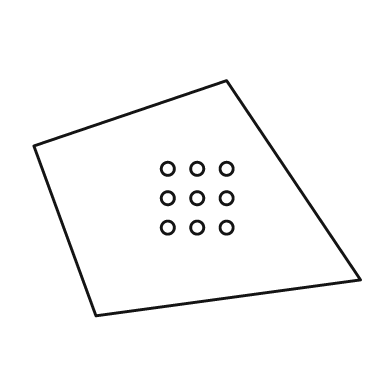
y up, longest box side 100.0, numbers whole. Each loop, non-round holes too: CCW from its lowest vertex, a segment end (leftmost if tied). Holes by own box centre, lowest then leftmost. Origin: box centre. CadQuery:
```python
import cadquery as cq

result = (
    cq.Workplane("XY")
    .moveTo(-31.0, -36.0)
    .lineTo(50.0, -25.0)
    .lineTo(9.0, 36.0)
    .lineTo(-50.0, 16.0)
    .close()
    .moveTo(-9.0, -9.0)
    .circle(2.0)
    .moveTo(0.0, -9.0)
    .circle(2.0)
    .moveTo(9.0, -9.0)
    .circle(2.0)
    .moveTo(-9.0, 0.0)
    .circle(2.0)
    .moveTo(0.0, 0.0)
    .circle(2.0)
    .moveTo(9.0, 0.0)
    .circle(2.0)
    .moveTo(-9.0, 9.0)
    .circle(2.0)
    .moveTo(0.0, 9.0)
    .circle(2.0)
    .moveTo(9.0, 9.0)
    .circle(2.0)
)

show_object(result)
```